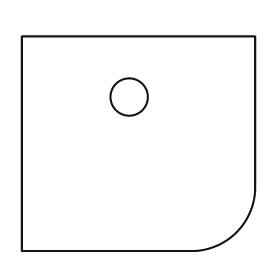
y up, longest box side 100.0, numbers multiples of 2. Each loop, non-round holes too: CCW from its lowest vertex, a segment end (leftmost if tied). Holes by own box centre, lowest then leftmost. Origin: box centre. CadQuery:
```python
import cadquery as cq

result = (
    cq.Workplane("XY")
    .moveTo(-50.0, -46.0)
    .lineTo(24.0, -46.0)
    .threePointArc((42.0, -38.0), (50.0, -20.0))
    .lineTo(50.0, 46.0)
    .lineTo(-50.0, 46.0)
    .close()
    .moveTo(-4.0, 20.0)
    .circle(8.0)
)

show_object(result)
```